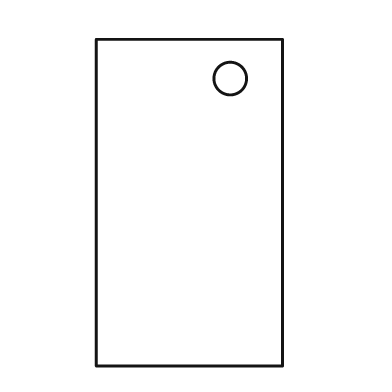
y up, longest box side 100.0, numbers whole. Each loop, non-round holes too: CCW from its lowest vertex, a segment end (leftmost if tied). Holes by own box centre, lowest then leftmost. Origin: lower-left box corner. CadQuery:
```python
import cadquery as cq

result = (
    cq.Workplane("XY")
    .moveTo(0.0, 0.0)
    .lineTo(57.0, 0.0)
    .lineTo(57.0, 100.0)
    .lineTo(0.0, 100.0)
    .close()
    .moveTo(41.0, 88.0)
    .circle(5.0)
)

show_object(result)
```